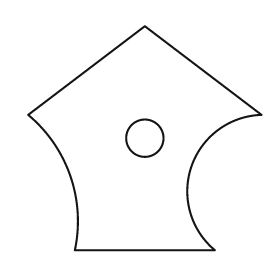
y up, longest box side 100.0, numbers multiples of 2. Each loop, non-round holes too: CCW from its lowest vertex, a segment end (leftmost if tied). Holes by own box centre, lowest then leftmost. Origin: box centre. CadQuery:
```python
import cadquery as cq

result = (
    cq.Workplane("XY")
    .moveTo(-30.0, -48.0)
    .lineTo(30.0, -48.0)
    .threePointArc((20.0, -12.0), (50.0, 10.0))
    .lineTo(0.0, 48.0)
    .lineTo(-50.0, 10.0)
    .threePointArc((-32.0, -16.0), (-30.0, -48.0))
    .close()
    .moveTo(0.0, 0.0)
    .circle(8.0)
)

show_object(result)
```